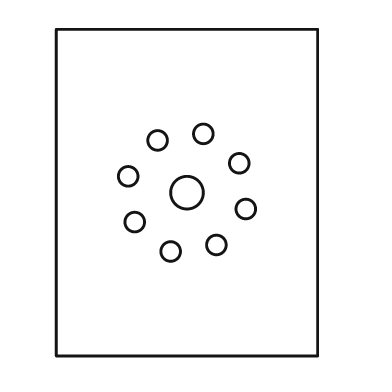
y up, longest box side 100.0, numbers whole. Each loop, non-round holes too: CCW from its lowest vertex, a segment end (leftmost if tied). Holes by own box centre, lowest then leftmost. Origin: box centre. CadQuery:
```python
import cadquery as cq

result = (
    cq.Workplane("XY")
    .moveTo(-40.0, -50.0)
    .lineTo(40.0, -50.0)
    .lineTo(40.0, 50.0)
    .lineTo(-40.0, 50.0)
    .close()
    .moveTo(-5.0, -18.0)
    .circle(3.0)
    .moveTo(9.0, -16.0)
    .circle(3.0)
    .moveTo(-16.0, -9.0)
    .circle(3.0)
    .moveTo(18.0, -5.0)
    .circle(3.0)
    .moveTo(0.0, 0.0)
    .circle(5.0)
    .moveTo(-18.0, 5.0)
    .circle(3.0)
    .moveTo(16.0, 9.0)
    .circle(3.0)
    .moveTo(-9.0, 16.0)
    .circle(3.0)
    .moveTo(5.0, 18.0)
    .circle(3.0)
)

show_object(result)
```